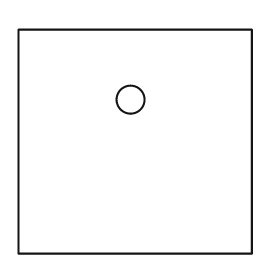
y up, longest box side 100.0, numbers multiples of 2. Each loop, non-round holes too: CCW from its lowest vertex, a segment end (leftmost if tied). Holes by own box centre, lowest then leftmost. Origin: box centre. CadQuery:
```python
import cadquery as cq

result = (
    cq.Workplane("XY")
    .moveTo(-50.0, -48.0)
    .lineTo(50.0, -48.0)
    .lineTo(50.0, 48.0)
    .lineTo(-50.0, 48.0)
    .close()
    .moveTo(-2.0, 18.0)
    .circle(6.0)
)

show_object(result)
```